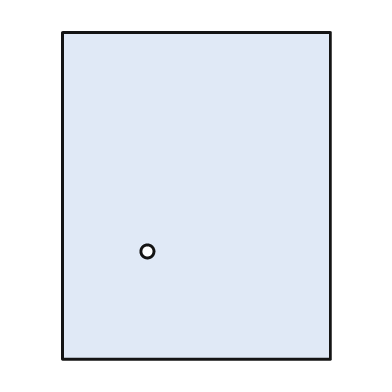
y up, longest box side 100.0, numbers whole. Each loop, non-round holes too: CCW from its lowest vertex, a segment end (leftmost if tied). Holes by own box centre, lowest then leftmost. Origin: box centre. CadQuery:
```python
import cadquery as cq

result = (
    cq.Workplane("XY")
    .moveTo(-41.0, -50.0)
    .lineTo(41.0, -50.0)
    .lineTo(41.0, 50.0)
    .lineTo(-41.0, 50.0)
    .close()
    .moveTo(-15.0, -17.0)
    .circle(2.0)
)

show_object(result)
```